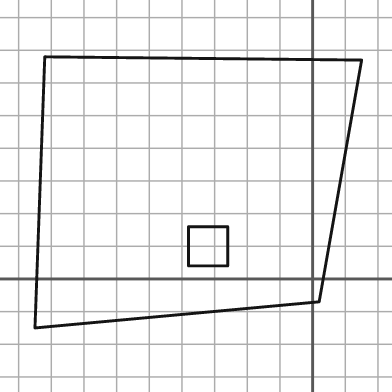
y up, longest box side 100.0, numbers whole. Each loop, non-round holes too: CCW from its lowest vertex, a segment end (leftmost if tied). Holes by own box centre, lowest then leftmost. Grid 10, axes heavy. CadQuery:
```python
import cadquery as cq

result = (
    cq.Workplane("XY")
    .moveTo(-85.0, -15.0)
    .lineTo(2.0, -7.0)
    .lineTo(15.0, 67.0)
    .lineTo(-82.0, 68.0)
    .close()
    .moveTo(-38.0, 4.0)
    .lineTo(-26.0, 4.0)
    .lineTo(-26.0, 16.0)
    .lineTo(-38.0, 16.0)
    .close()
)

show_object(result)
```